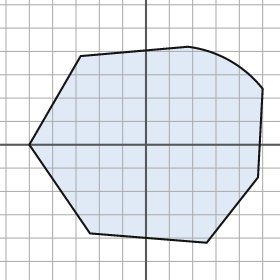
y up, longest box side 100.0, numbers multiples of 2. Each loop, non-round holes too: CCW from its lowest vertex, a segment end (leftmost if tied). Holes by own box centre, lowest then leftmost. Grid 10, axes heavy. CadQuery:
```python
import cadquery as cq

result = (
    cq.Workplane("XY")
    .moveTo(26.0, -42.0)
    .lineTo(48.0, -14.0)
    .lineTo(50.0, 24.0)
    .threePointArc((36.0, 36.0), (18.0, 42.0))
    .lineTo(-28.0, 38.0)
    .lineTo(-50.0, 0.0)
    .lineTo(-24.0, -38.0)
    .close()
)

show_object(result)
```